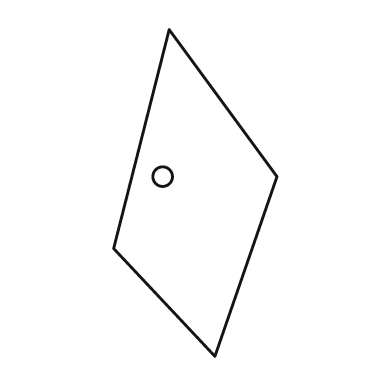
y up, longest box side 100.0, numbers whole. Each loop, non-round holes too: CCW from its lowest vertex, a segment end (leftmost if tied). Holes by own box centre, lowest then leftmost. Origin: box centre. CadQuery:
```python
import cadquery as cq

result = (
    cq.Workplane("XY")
    .moveTo(6.0, -50.0)
    .lineTo(25.0, 5.0)
    .lineTo(-8.0, 50.0)
    .lineTo(-25.0, -17.0)
    .close()
    .moveTo(-10.0, 5.0)
    .circle(3.0)
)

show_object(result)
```